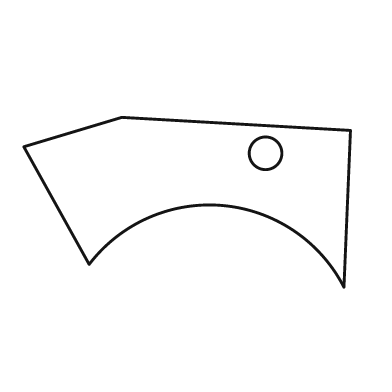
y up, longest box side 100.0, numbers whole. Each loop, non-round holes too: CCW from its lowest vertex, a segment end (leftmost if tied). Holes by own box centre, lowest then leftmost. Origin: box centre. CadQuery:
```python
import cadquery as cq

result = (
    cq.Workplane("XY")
    .moveTo(48.0, -26.0)
    .lineTo(50.0, 22.0)
    .lineTo(-20.0, 26.0)
    .lineTo(-50.0, 17.0)
    .lineTo(-30.0, -19.0)
    .threePointArc((11.0, -1.0), (48.0, -26.0))
    .close()
    .moveTo(24.0, 15.0)
    .circle(5.0)
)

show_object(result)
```